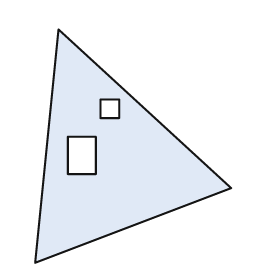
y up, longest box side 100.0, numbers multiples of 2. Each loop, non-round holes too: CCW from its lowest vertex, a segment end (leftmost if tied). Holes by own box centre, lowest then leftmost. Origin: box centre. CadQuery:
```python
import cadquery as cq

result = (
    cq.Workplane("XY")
    .moveTo(-42.0, -50.0)
    .lineTo(42.0, -18.0)
    .lineTo(-32.0, 50.0)
    .close()
    .moveTo(-28.0, -12.0)
    .lineTo(-16.0, -12.0)
    .lineTo(-16.0, 4.0)
    .lineTo(-28.0, 4.0)
    .close()
    .moveTo(-14.0, 12.0)
    .lineTo(-6.0, 12.0)
    .lineTo(-6.0, 20.0)
    .lineTo(-14.0, 20.0)
    .close()
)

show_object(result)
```